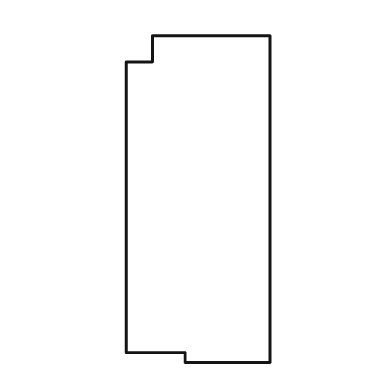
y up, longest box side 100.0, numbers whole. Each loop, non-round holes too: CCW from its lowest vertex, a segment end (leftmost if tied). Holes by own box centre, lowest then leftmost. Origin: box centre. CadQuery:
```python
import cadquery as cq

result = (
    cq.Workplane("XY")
    .moveTo(-4.0, -50.0)
    .lineTo(22.0, -50.0)
    .lineTo(22.0, 50.0)
    .lineTo(-14.0, 50.0)
    .lineTo(-14.0, 42.0)
    .lineTo(-22.0, 42.0)
    .lineTo(-22.0, -47.0)
    .lineTo(-4.0, -47.0)
    .close()
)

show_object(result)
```